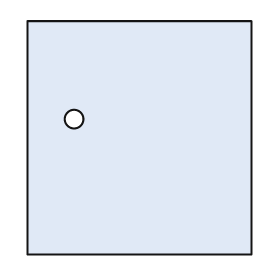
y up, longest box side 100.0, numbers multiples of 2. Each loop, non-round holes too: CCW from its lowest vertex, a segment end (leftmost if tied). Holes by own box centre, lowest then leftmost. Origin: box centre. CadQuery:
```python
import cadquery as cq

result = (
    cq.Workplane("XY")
    .moveTo(-48.0, -50.0)
    .lineTo(48.0, -50.0)
    .lineTo(48.0, 50.0)
    .lineTo(-48.0, 50.0)
    .close()
    .moveTo(-28.0, 8.0)
    .circle(4.0)
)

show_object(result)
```